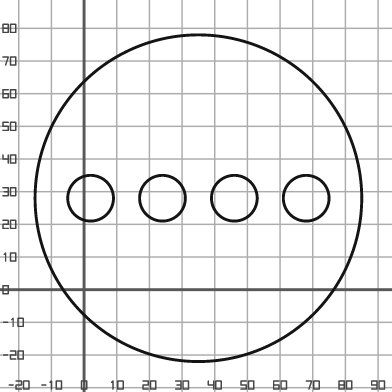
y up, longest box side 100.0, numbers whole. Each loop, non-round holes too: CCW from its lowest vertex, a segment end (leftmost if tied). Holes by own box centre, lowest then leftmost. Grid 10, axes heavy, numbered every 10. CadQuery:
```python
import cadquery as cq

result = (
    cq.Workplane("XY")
    .moveTo(35.0, 28.0)
    .circle(50.0)
    .moveTo(2.0, 28.0)
    .circle(7.0)
    .moveTo(24.0, 28.0)
    .circle(7.0)
    .moveTo(46.0, 28.0)
    .circle(7.0)
    .moveTo(68.0, 28.0)
    .circle(7.0)
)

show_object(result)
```